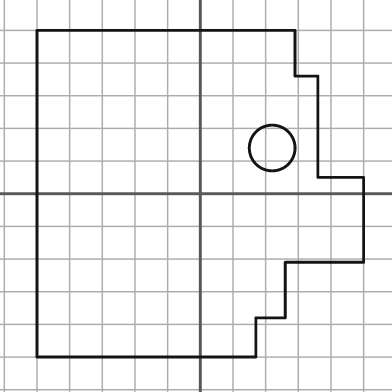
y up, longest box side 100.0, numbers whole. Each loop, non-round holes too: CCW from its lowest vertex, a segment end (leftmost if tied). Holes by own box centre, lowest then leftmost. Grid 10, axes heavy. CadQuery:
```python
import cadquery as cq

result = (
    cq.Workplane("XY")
    .moveTo(-50.0, -50.0)
    .lineTo(17.0, -50.0)
    .lineTo(17.0, -38.0)
    .lineTo(26.0, -38.0)
    .lineTo(26.0, -21.0)
    .lineTo(50.0, -21.0)
    .lineTo(50.0, 5.0)
    .lineTo(36.0, 5.0)
    .lineTo(36.0, 36.0)
    .lineTo(29.0, 36.0)
    .lineTo(29.0, 50.0)
    .lineTo(-50.0, 50.0)
    .close()
    .moveTo(22.0, 14.0)
    .circle(7.0)
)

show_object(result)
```